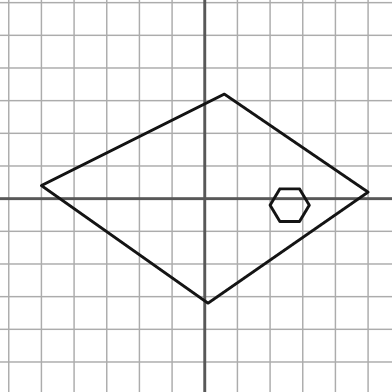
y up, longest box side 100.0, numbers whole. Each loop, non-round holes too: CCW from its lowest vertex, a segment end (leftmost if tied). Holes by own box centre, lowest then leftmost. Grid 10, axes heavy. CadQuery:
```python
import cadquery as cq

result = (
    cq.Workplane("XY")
    .moveTo(1.0, -32.0)
    .lineTo(50.0, 2.0)
    .lineTo(6.0, 32.0)
    .lineTo(-50.0, 4.0)
    .close()
    .moveTo(23.0, -7.0)
    .lineTo(29.0, -7.0)
    .lineTo(32.0, -2.0)
    .lineTo(29.0, 3.0)
    .lineTo(23.0, 3.0)
    .lineTo(20.0, -2.0)
    .close()
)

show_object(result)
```